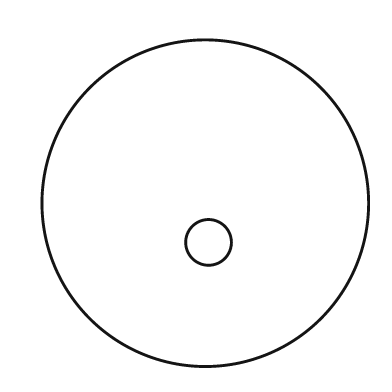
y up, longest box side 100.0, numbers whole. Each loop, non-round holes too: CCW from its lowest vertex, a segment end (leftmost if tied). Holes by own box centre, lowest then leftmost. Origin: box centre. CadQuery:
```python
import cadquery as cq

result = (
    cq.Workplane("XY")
    .moveTo(0.0, 0.0)
    .circle(50.0)
    .moveTo(1.0, -12.0)
    .circle(7.0)
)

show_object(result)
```